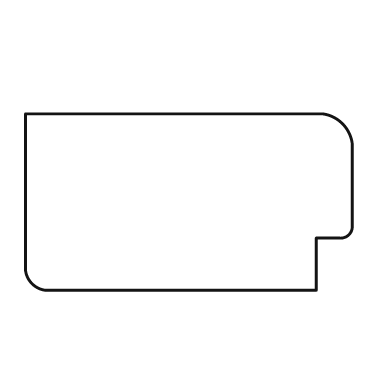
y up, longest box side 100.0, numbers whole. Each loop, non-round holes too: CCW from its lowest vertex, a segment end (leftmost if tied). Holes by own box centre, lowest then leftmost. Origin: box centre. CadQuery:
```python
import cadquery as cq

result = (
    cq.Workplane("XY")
    .moveTo(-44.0, -27.0)
    .lineTo(39.0, -27.0)
    .lineTo(39.0, -11.0)
    .lineTo(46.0, -11.0)
    .threePointArc((49.0, -10.0), (50.0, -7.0))
    .lineTo(50.0, 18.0)
    .threePointArc((47.0, 24.0), (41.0, 27.0))
    .lineTo(-50.0, 27.0)
    .lineTo(-50.0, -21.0)
    .threePointArc((-48.0, -25.0), (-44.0, -27.0))
    .close()
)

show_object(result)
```